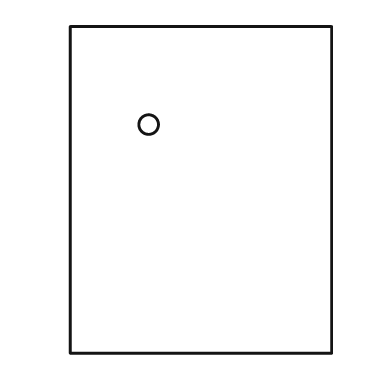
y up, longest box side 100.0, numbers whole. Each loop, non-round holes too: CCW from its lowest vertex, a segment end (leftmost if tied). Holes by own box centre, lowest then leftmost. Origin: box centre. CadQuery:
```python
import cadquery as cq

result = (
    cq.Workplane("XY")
    .moveTo(-40.0, -50.0)
    .lineTo(40.0, -50.0)
    .lineTo(40.0, 50.0)
    .lineTo(-40.0, 50.0)
    .close()
    .moveTo(-16.0, 20.0)
    .circle(3.0)
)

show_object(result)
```